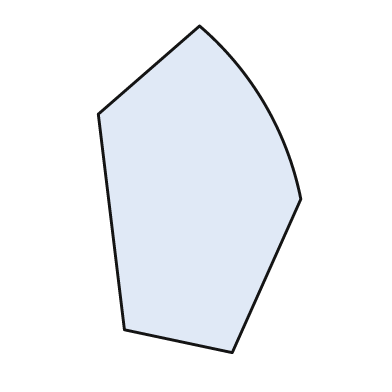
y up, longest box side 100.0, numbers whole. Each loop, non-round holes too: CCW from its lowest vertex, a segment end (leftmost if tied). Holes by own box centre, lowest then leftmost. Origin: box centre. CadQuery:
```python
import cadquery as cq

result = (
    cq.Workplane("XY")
    .moveTo(10.0, -50.0)
    .lineTo(31.0, -3.0)
    .threePointArc((20.0, 26.0), (0.0, 50.0))
    .lineTo(-31.0, 23.0)
    .lineTo(-23.0, -43.0)
    .close()
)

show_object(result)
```